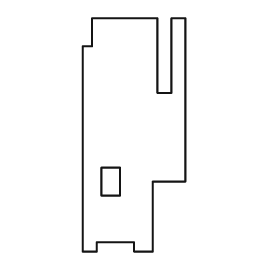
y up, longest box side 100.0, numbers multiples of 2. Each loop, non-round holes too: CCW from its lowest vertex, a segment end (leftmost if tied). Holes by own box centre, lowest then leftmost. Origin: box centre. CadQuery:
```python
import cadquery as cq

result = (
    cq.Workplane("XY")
    .moveTo(-22.0, -50.0)
    .lineTo(-16.0, -50.0)
    .lineTo(-16.0, -46.0)
    .lineTo(0.0, -46.0)
    .lineTo(0.0, -50.0)
    .lineTo(8.0, -50.0)
    .lineTo(8.0, -20.0)
    .lineTo(22.0, -20.0)
    .lineTo(22.0, 50.0)
    .lineTo(16.0, 50.0)
    .lineTo(16.0, 18.0)
    .lineTo(10.0, 18.0)
    .lineTo(10.0, 50.0)
    .lineTo(-18.0, 50.0)
    .lineTo(-18.0, 38.0)
    .lineTo(-22.0, 38.0)
    .close()
    .moveTo(-14.0, -26.0)
    .lineTo(-6.0, -26.0)
    .lineTo(-6.0, -14.0)
    .lineTo(-14.0, -14.0)
    .close()
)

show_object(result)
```